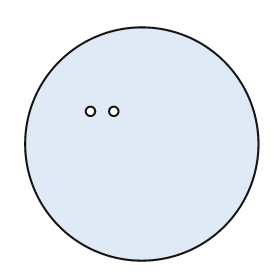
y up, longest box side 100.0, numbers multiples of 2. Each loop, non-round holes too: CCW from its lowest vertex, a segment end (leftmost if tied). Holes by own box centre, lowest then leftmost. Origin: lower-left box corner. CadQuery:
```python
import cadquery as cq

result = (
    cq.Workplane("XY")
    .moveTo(50.0, 50.0)
    .circle(50.0)
    .moveTo(28.0, 64.0)
    .circle(2.0)
    .moveTo(38.0, 64.0)
    .circle(2.0)
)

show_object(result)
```